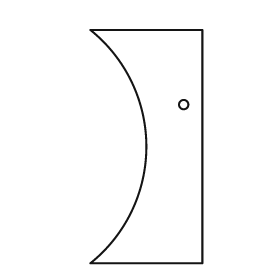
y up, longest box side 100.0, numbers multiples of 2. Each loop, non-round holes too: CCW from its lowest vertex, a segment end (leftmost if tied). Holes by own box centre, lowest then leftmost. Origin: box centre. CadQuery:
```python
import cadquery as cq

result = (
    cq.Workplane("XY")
    .moveTo(-24.0, -50.0)
    .lineTo(24.0, -50.0)
    .lineTo(24.0, 50.0)
    .lineTo(-24.0, 50.0)
    .threePointArc((0.0, 0.0), (-24.0, -50.0))
    .close()
    .moveTo(16.0, 18.0)
    .circle(2.0)
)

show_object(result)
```